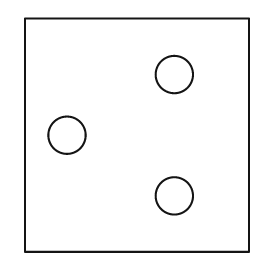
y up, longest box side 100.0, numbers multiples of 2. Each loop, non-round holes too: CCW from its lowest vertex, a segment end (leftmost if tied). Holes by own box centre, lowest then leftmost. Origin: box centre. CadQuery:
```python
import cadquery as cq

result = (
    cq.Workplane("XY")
    .moveTo(-48.0, -50.0)
    .lineTo(48.0, -50.0)
    .lineTo(48.0, 50.0)
    .lineTo(-48.0, 50.0)
    .close()
    .moveTo(16.0, -26.0)
    .circle(8.0)
    .moveTo(-30.0, 0.0)
    .circle(8.0)
    .moveTo(16.0, 26.0)
    .circle(8.0)
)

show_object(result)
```